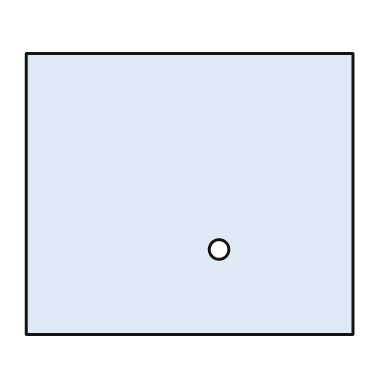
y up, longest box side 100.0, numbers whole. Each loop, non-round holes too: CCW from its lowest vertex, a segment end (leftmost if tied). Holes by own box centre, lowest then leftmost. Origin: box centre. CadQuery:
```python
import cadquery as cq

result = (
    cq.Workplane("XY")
    .moveTo(-50.0, -43.0)
    .lineTo(50.0, -43.0)
    .lineTo(50.0, 43.0)
    .lineTo(-50.0, 43.0)
    .close()
    .moveTo(9.0, -17.0)
    .circle(3.0)
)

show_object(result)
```